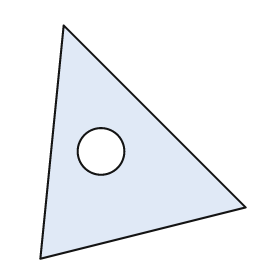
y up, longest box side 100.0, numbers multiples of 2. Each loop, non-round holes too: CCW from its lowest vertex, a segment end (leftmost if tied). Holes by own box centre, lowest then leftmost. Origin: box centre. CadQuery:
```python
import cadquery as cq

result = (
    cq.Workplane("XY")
    .moveTo(-44.0, -50.0)
    .lineTo(44.0, -28.0)
    .lineTo(-34.0, 50.0)
    .close()
    .moveTo(-18.0, -4.0)
    .circle(10.0)
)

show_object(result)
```